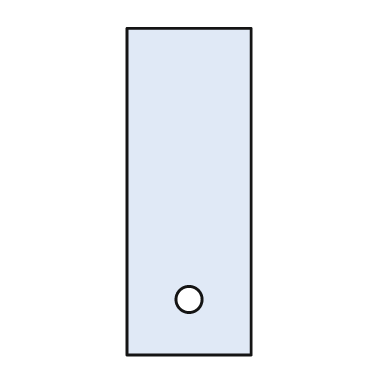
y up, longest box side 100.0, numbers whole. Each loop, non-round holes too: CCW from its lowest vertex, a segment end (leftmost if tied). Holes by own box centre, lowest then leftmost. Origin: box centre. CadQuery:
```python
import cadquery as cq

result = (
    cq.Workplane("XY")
    .moveTo(-19.0, -50.0)
    .lineTo(19.0, -50.0)
    .lineTo(19.0, 50.0)
    .lineTo(-19.0, 50.0)
    .close()
    .moveTo(0.0, -33.0)
    .circle(4.0)
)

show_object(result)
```